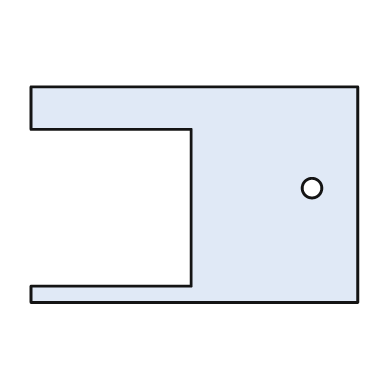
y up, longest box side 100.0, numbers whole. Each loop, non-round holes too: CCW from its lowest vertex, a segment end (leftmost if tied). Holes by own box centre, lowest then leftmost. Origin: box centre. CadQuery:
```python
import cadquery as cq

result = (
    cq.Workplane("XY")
    .moveTo(-50.0, -33.0)
    .lineTo(50.0, -33.0)
    .lineTo(50.0, 33.0)
    .lineTo(-50.0, 33.0)
    .lineTo(-50.0, 20.0)
    .lineTo(-1.0, 20.0)
    .lineTo(-1.0, -28.0)
    .lineTo(-50.0, -28.0)
    .close()
    .moveTo(36.0, 2.0)
    .circle(3.0)
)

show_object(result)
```